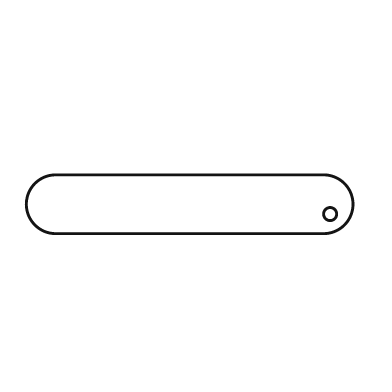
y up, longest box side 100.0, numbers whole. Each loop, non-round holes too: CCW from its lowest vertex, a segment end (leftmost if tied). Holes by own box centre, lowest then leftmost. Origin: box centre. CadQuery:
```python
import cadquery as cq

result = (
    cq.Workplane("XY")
    .moveTo(-41.0, -9.0)
    .lineTo(41.0, -9.0)
    .threePointArc((50.0, 0.0), (41.0, 9.0))
    .lineTo(-41.0, 9.0)
    .threePointArc((-50.0, 0.0), (-41.0, -9.0))
    .close()
    .moveTo(43.0, -3.0)
    .circle(2.0)
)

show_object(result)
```